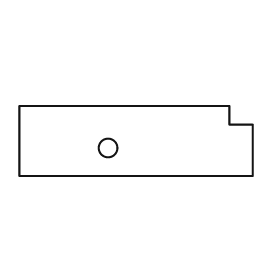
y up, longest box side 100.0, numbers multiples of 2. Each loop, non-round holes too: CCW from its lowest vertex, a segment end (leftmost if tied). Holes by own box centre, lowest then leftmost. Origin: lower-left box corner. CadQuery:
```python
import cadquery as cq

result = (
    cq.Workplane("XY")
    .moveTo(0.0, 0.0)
    .lineTo(100.0, 0.0)
    .lineTo(100.0, 22.0)
    .lineTo(90.0, 22.0)
    .lineTo(90.0, 30.0)
    .lineTo(0.0, 30.0)
    .close()
    .moveTo(38.0, 12.0)
    .circle(4.0)
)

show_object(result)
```